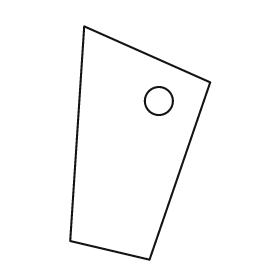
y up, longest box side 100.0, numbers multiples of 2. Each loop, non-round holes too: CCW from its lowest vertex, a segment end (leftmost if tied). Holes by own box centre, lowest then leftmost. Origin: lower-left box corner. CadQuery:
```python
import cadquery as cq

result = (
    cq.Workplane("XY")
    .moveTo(34.0, 0.0)
    .lineTo(60.0, 76.0)
    .lineTo(6.0, 100.0)
    .lineTo(0.0, 8.0)
    .close()
    .moveTo(38.0, 68.0)
    .circle(6.0)
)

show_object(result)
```